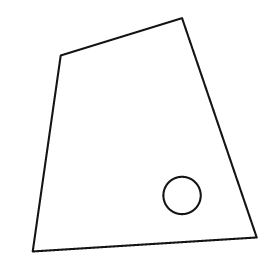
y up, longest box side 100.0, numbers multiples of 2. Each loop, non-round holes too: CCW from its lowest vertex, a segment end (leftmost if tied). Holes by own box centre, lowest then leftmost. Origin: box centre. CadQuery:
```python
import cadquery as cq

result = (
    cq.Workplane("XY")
    .moveTo(-48.0, -50.0)
    .lineTo(48.0, -44.0)
    .lineTo(16.0, 50.0)
    .lineTo(-36.0, 34.0)
    .close()
    .moveTo(16.0, -26.0)
    .circle(8.0)
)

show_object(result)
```